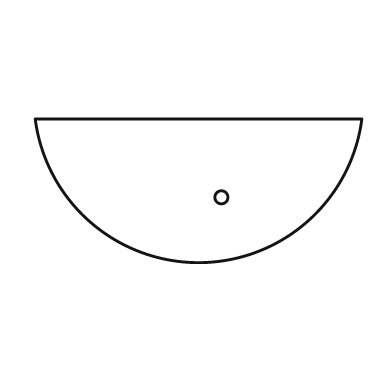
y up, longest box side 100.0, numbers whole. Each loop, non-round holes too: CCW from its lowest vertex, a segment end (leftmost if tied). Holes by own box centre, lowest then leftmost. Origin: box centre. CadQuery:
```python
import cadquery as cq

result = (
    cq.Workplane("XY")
    .moveTo(-50.0, 22.0)
    .threePointArc((0.0, -22.0), (50.0, 22.0))
    .close()
    .moveTo(7.0, -2.0)
    .circle(2.0)
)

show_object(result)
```